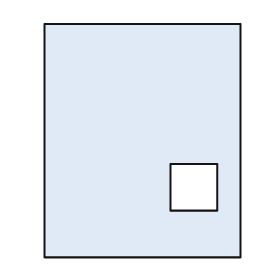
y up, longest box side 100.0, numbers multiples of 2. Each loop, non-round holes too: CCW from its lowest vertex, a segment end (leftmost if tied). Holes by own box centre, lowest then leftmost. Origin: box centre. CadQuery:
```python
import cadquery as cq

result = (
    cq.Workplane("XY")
    .moveTo(-42.0, -50.0)
    .lineTo(42.0, -50.0)
    .lineTo(42.0, 50.0)
    .lineTo(-42.0, 50.0)
    .close()
    .moveTo(12.0, -30.0)
    .lineTo(32.0, -30.0)
    .lineTo(32.0, -10.0)
    .lineTo(12.0, -10.0)
    .close()
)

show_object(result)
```